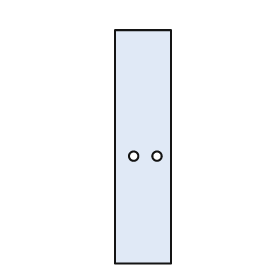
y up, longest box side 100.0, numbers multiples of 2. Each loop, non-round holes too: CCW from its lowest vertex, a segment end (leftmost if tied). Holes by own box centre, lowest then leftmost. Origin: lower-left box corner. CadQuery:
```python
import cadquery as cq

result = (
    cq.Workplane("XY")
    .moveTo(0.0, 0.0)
    .lineTo(24.0, 0.0)
    .lineTo(24.0, 100.0)
    .lineTo(0.0, 100.0)
    .close()
    .moveTo(8.0, 46.0)
    .circle(2.0)
    .moveTo(18.0, 46.0)
    .circle(2.0)
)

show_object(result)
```